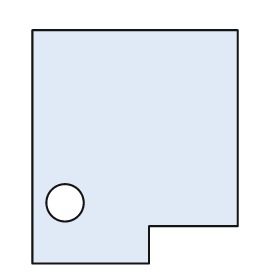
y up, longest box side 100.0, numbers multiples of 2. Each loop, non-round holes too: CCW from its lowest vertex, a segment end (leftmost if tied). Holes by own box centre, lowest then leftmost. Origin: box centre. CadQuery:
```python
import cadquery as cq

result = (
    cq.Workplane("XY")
    .moveTo(-44.0, -50.0)
    .lineTo(6.0, -50.0)
    .lineTo(6.0, -34.0)
    .lineTo(44.0, -34.0)
    .lineTo(44.0, 50.0)
    .lineTo(-44.0, 50.0)
    .close()
    .moveTo(-30.0, -24.0)
    .circle(8.0)
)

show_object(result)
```